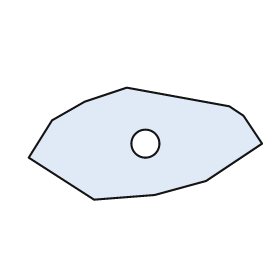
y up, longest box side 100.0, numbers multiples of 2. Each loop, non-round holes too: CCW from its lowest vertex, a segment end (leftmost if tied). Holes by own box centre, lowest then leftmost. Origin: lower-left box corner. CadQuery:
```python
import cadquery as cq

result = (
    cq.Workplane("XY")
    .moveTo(28.0, 0.0)
    .lineTo(54.0, 2.0)
    .lineTo(76.0, 8.0)
    .lineTo(100.0, 24.0)
    .lineTo(92.0, 36.0)
    .lineTo(86.0, 40.0)
    .lineTo(42.0, 48.0)
    .lineTo(24.0, 42.0)
    .lineTo(10.0, 34.0)
    .lineTo(0.0, 18.0)
    .close()
    .moveTo(50.0, 24.0)
    .circle(6.0)
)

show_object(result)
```